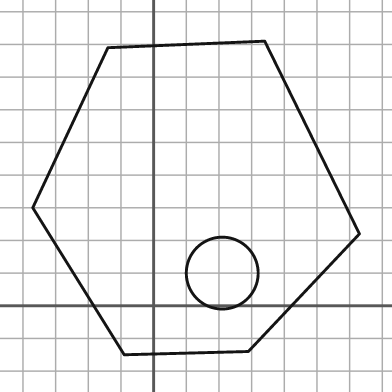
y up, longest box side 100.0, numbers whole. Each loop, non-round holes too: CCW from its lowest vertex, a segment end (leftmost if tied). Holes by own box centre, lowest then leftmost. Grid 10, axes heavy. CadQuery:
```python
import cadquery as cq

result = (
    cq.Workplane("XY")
    .moveTo(-9.0, -15.0)
    .lineTo(29.0, -14.0)
    .lineTo(63.0, 22.0)
    .lineTo(34.0, 81.0)
    .lineTo(-14.0, 79.0)
    .lineTo(-37.0, 30.0)
    .close()
    .moveTo(21.0, 10.0)
    .circle(11.0)
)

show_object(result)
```